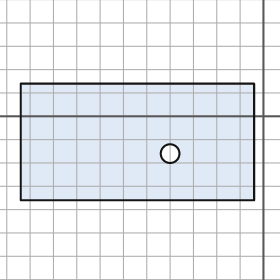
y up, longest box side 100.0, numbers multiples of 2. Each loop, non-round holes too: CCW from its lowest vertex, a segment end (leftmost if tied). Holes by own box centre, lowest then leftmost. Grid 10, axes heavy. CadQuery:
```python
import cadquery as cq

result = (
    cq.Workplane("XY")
    .moveTo(-104.0, -36.0)
    .lineTo(-4.0, -36.0)
    .lineTo(-4.0, 14.0)
    .lineTo(-104.0, 14.0)
    .close()
    .moveTo(-40.0, -16.0)
    .circle(4.0)
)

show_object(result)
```